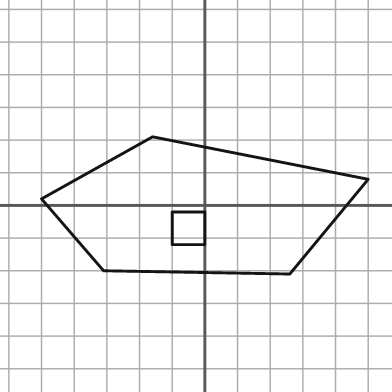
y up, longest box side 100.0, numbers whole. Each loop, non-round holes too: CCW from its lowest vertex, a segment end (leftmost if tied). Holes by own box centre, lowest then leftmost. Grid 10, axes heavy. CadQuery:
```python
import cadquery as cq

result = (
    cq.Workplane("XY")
    .moveTo(26.0, -21.0)
    .lineTo(50.0, 8.0)
    .lineTo(-16.0, 21.0)
    .lineTo(-50.0, 2.0)
    .lineTo(-31.0, -20.0)
    .close()
    .moveTo(-10.0, -12.0)
    .lineTo(0.0, -12.0)
    .lineTo(0.0, -2.0)
    .lineTo(-10.0, -2.0)
    .close()
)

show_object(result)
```